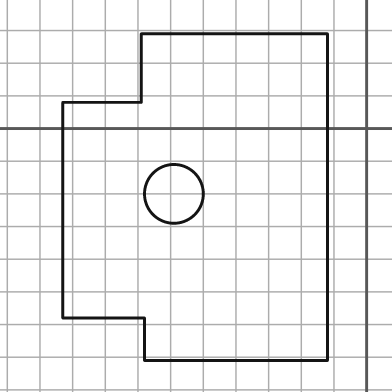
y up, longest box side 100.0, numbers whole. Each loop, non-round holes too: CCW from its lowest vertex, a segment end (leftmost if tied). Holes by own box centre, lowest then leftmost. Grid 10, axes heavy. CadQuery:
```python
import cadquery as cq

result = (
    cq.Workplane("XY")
    .moveTo(-68.0, -71.0)
    .lineTo(-12.0, -71.0)
    .lineTo(-12.0, 29.0)
    .lineTo(-69.0, 29.0)
    .lineTo(-69.0, 8.0)
    .lineTo(-93.0, 8.0)
    .lineTo(-93.0, -58.0)
    .lineTo(-68.0, -58.0)
    .close()
    .moveTo(-59.0, -20.0)
    .circle(9.0)
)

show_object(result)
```